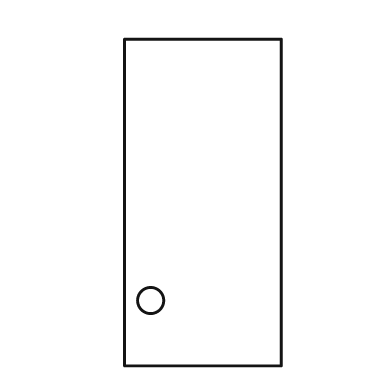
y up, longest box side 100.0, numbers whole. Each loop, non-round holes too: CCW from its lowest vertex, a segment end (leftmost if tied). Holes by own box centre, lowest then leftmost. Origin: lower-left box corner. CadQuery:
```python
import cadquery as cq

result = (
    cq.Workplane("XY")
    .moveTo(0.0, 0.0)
    .lineTo(48.0, 0.0)
    .lineTo(48.0, 100.0)
    .lineTo(0.0, 100.0)
    .close()
    .moveTo(8.0, 20.0)
    .circle(4.0)
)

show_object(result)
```